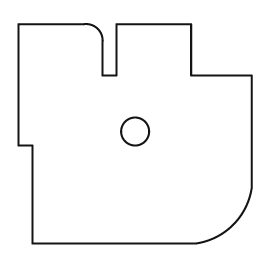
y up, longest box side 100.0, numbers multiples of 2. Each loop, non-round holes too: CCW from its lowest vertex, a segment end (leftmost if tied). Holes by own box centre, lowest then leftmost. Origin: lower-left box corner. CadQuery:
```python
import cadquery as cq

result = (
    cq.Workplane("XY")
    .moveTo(6.0, 0.0)
    .lineTo(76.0, 0.0)
    .threePointArc((92.0, 8.0), (100.0, 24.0))
    .lineTo(100.0, 72.0)
    .lineTo(74.0, 72.0)
    .lineTo(74.0, 94.0)
    .lineTo(42.0, 94.0)
    .lineTo(42.0, 72.0)
    .lineTo(36.0, 72.0)
    .lineTo(36.0, 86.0)
    .threePointArc((34.0, 92.0), (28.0, 94.0))
    .lineTo(0.0, 94.0)
    .lineTo(0.0, 42.0)
    .lineTo(6.0, 42.0)
    .close()
    .moveTo(50.0, 48.0)
    .circle(6.0)
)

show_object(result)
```